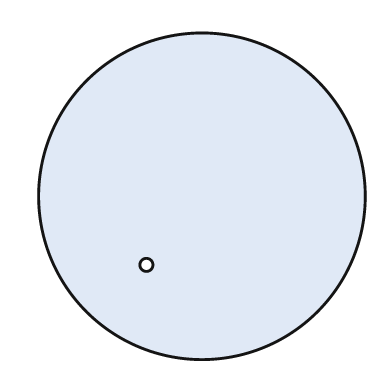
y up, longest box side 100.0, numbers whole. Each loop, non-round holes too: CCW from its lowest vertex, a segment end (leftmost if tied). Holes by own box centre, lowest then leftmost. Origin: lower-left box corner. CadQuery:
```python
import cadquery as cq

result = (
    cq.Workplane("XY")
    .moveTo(50.0, 50.0)
    .circle(50.0)
    .moveTo(33.0, 29.0)
    .circle(2.0)
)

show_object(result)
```